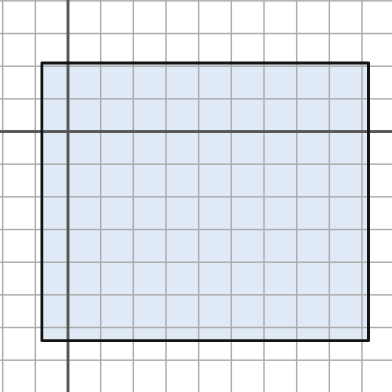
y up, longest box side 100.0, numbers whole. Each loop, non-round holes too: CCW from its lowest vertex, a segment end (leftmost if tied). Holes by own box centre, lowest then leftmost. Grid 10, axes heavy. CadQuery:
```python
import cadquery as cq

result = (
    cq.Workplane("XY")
    .moveTo(-8.0, -64.0)
    .lineTo(92.0, -64.0)
    .lineTo(92.0, 21.0)
    .lineTo(-8.0, 21.0)
    .close()
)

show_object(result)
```